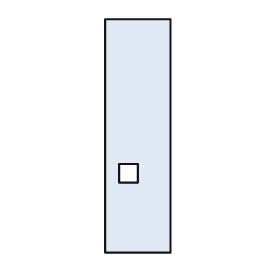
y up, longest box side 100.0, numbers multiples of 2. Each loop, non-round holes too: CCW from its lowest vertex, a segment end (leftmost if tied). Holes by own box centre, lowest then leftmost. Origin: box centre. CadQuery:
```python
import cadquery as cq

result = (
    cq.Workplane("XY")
    .moveTo(-14.0, -50.0)
    .lineTo(14.0, -50.0)
    .lineTo(14.0, 50.0)
    .lineTo(-14.0, 50.0)
    .close()
    .moveTo(-8.0, -20.0)
    .lineTo(0.0, -20.0)
    .lineTo(0.0, -12.0)
    .lineTo(-8.0, -12.0)
    .close()
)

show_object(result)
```